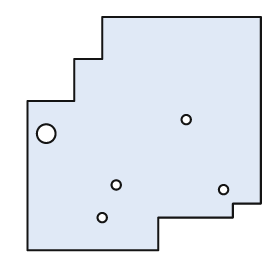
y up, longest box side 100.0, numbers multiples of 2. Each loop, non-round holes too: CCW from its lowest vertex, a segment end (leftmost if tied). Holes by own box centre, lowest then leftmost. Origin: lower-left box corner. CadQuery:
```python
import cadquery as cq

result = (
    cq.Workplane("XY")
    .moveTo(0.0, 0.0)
    .lineTo(56.0, 0.0)
    .lineTo(56.0, 14.0)
    .lineTo(88.0, 14.0)
    .lineTo(88.0, 20.0)
    .lineTo(100.0, 20.0)
    .lineTo(100.0, 100.0)
    .lineTo(32.0, 100.0)
    .lineTo(32.0, 82.0)
    .lineTo(20.0, 82.0)
    .lineTo(20.0, 64.0)
    .lineTo(0.0, 64.0)
    .close()
    .moveTo(32.0, 14.0)
    .circle(2.0)
    .moveTo(84.0, 26.0)
    .circle(2.0)
    .moveTo(38.0, 28.0)
    .circle(2.0)
    .moveTo(8.0, 50.0)
    .circle(4.0)
    .moveTo(68.0, 56.0)
    .circle(2.0)
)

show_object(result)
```